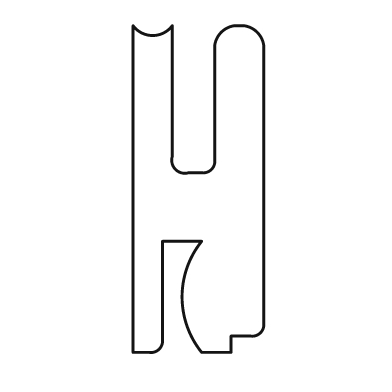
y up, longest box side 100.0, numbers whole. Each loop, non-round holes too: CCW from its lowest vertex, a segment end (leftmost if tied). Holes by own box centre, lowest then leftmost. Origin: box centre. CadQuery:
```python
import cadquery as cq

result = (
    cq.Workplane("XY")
    .moveTo(-20.0, -50.0)
    .lineTo(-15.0, -50.0)
    .threePointArc((-12.0, -49.0), (-11.0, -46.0))
    .lineTo(-11.0, -16.0)
    .lineTo(1.0, -16.0)
    .threePointArc((-5.0, -33.0), (1.0, -50.0))
    .lineTo(10.0, -50.0)
    .lineTo(10.0, -45.0)
    .lineTo(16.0, -45.0)
    .threePointArc((19.0, -44.0), (20.0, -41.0))
    .lineTo(20.0, 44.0)
    .threePointArc((18.0, 48.0), (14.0, 50.0))
    .lineTo(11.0, 50.0)
    .threePointArc((7.0, 48.0), (5.0, 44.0))
    .lineTo(5.0, 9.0)
    .threePointArc((4.0, 6.0), (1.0, 5.0))
    .lineTo(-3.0, 5.0)
    .threePointArc((-7.0, 6.0), (-8.0, 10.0))
    .lineTo(-8.0, 50.0)
    .threePointArc((-14.0, 47.0), (-20.0, 50.0))
    .close()
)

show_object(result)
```